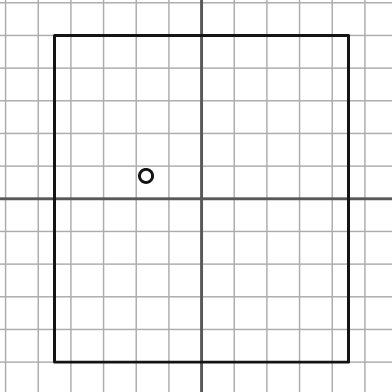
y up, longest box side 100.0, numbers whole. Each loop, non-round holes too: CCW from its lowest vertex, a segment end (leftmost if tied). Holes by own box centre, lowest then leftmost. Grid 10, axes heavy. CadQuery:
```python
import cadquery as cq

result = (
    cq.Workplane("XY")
    .moveTo(-45.0, -50.0)
    .lineTo(45.0, -50.0)
    .lineTo(45.0, 50.0)
    .lineTo(-45.0, 50.0)
    .close()
    .moveTo(-17.0, 7.0)
    .circle(2.0)
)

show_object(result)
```